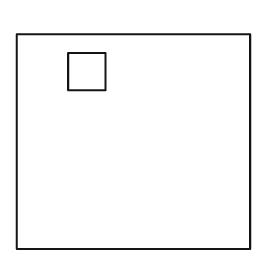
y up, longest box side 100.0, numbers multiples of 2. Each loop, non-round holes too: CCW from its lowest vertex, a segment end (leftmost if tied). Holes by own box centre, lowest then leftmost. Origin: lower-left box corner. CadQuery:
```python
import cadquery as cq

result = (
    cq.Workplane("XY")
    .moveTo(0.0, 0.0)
    .lineTo(100.0, 0.0)
    .lineTo(100.0, 92.0)
    .lineTo(0.0, 92.0)
    .close()
    .moveTo(22.0, 68.0)
    .lineTo(38.0, 68.0)
    .lineTo(38.0, 84.0)
    .lineTo(22.0, 84.0)
    .close()
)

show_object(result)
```